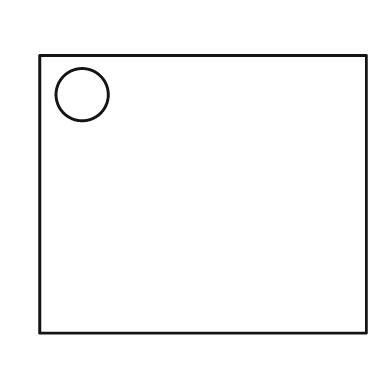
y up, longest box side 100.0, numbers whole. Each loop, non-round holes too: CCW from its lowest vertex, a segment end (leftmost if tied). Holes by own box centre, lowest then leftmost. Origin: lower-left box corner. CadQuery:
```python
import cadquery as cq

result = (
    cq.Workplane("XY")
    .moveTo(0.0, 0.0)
    .lineTo(100.0, 0.0)
    .lineTo(100.0, 85.0)
    .lineTo(0.0, 85.0)
    .close()
    .moveTo(13.0, 73.0)
    .circle(8.0)
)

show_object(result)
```